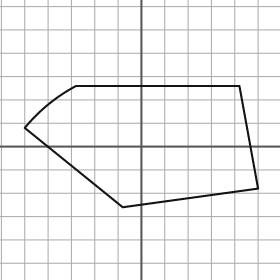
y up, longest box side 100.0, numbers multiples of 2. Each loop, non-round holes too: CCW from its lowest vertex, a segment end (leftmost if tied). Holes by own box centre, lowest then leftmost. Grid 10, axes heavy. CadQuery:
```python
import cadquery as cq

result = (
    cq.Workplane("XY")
    .moveTo(-8.0, -26.0)
    .lineTo(50.0, -18.0)
    .lineTo(42.0, 26.0)
    .lineTo(-28.0, 26.0)
    .threePointArc((-40.0, 18.0), (-50.0, 8.0))
    .close()
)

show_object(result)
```